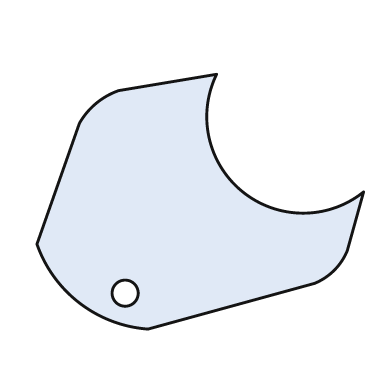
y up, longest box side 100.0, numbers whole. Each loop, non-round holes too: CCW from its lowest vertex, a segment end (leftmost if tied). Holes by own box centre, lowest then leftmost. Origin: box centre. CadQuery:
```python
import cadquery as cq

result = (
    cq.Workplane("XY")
    .moveTo(-16.0, -39.0)
    .lineTo(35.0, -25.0)
    .threePointArc((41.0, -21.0), (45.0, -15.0))
    .lineTo(50.0, 3.0)
    .threePointArc((13.0, 3.0), (5.0, 39.0))
    .lineTo(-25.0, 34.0)
    .threePointArc((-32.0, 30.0), (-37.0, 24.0))
    .lineTo(-50.0, -13.0)
    .threePointArc((-37.0, -31.0), (-16.0, -39.0))
    .close()
    .moveTo(-23.0, -28.0)
    .circle(4.0)
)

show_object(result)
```